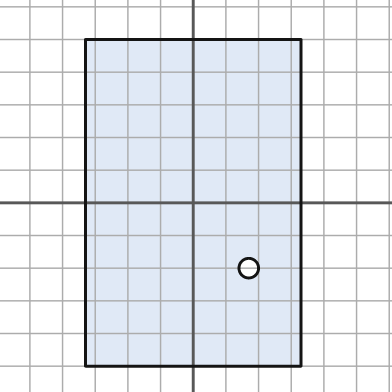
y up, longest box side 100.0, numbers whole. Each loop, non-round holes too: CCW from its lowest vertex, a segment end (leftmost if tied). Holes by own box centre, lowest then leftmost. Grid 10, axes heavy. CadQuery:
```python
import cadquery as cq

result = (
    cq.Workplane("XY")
    .moveTo(-33.0, -50.0)
    .lineTo(33.0, -50.0)
    .lineTo(33.0, 50.0)
    .lineTo(-33.0, 50.0)
    .close()
    .moveTo(17.0, -20.0)
    .circle(3.0)
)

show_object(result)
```